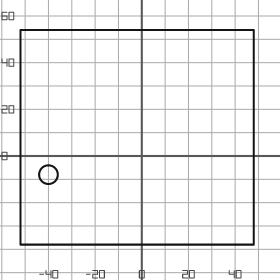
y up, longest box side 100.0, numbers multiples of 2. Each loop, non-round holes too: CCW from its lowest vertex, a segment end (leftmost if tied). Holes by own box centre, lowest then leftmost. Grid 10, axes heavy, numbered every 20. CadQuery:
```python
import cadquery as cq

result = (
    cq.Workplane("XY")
    .moveTo(-52.0, -38.0)
    .lineTo(48.0, -38.0)
    .lineTo(48.0, 54.0)
    .lineTo(-52.0, 54.0)
    .close()
    .moveTo(-40.0, -8.0)
    .circle(4.0)
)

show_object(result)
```